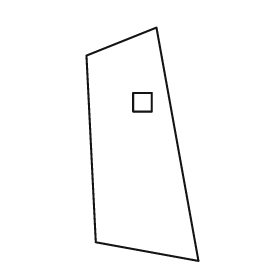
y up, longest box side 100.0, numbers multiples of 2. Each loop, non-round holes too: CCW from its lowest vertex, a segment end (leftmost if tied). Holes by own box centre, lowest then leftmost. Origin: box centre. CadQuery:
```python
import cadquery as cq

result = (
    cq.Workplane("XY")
    .moveTo(24.0, -50.0)
    .lineTo(6.0, 50.0)
    .lineTo(-24.0, 38.0)
    .lineTo(-20.0, -42.0)
    .close()
    .moveTo(-4.0, 14.0)
    .lineTo(4.0, 14.0)
    .lineTo(4.0, 22.0)
    .lineTo(-4.0, 22.0)
    .close()
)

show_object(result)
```